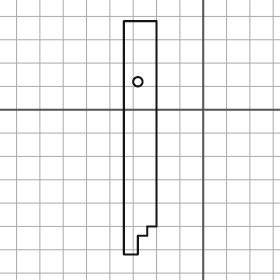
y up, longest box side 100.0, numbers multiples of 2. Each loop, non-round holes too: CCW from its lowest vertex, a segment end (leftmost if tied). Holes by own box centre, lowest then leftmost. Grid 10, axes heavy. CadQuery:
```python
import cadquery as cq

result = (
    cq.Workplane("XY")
    .moveTo(-34.0, -62.0)
    .lineTo(-28.0, -62.0)
    .lineTo(-28.0, -54.0)
    .lineTo(-24.0, -54.0)
    .lineTo(-24.0, -50.0)
    .lineTo(-20.0, -50.0)
    .lineTo(-20.0, 38.0)
    .lineTo(-34.0, 38.0)
    .close()
    .moveTo(-28.0, 12.0)
    .circle(2.0)
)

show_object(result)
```